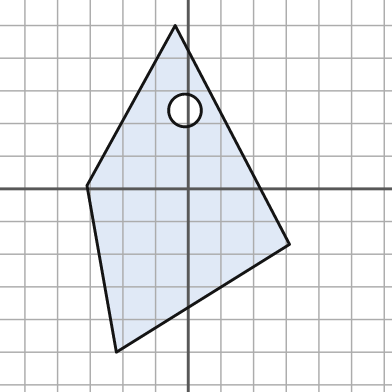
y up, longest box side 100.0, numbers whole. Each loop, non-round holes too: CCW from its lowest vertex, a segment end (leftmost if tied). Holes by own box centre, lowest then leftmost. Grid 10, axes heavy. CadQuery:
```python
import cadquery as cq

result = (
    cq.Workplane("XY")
    .moveTo(-22.0, -50.0)
    .lineTo(31.0, -17.0)
    .lineTo(-4.0, 50.0)
    .lineTo(-31.0, 1.0)
    .close()
    .moveTo(-1.0, 24.0)
    .circle(5.0)
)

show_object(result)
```